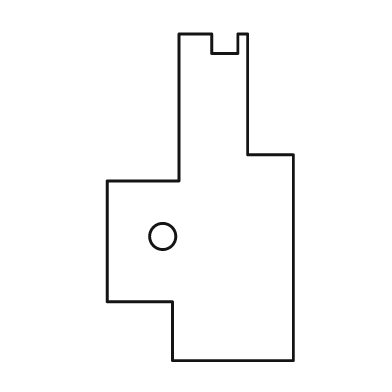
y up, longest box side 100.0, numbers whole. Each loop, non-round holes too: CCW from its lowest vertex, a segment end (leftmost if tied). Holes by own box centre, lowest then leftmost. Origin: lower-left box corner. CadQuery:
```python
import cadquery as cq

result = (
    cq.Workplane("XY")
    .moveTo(20.0, 0.0)
    .lineTo(57.0, 0.0)
    .lineTo(57.0, 63.0)
    .lineTo(43.0, 63.0)
    .lineTo(43.0, 100.0)
    .lineTo(40.0, 100.0)
    .lineTo(40.0, 94.0)
    .lineTo(32.0, 94.0)
    .lineTo(32.0, 100.0)
    .lineTo(22.0, 100.0)
    .lineTo(22.0, 55.0)
    .lineTo(0.0, 55.0)
    .lineTo(0.0, 18.0)
    .lineTo(20.0, 18.0)
    .close()
    .moveTo(17.0, 38.0)
    .circle(4.0)
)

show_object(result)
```